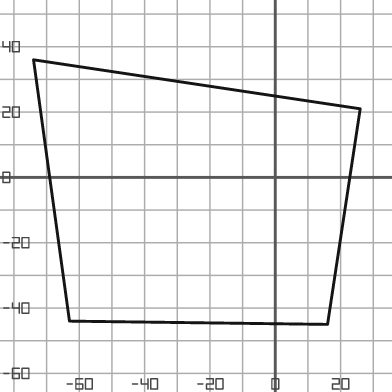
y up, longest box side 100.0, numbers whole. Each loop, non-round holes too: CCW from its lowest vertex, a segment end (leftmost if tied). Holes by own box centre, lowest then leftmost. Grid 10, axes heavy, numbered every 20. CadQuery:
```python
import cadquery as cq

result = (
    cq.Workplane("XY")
    .moveTo(16.0, -45.0)
    .lineTo(26.0, 21.0)
    .lineTo(-74.0, 36.0)
    .lineTo(-63.0, -44.0)
    .close()
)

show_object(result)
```